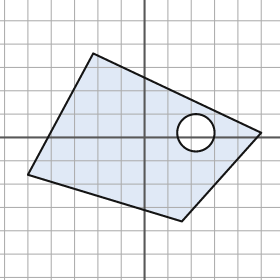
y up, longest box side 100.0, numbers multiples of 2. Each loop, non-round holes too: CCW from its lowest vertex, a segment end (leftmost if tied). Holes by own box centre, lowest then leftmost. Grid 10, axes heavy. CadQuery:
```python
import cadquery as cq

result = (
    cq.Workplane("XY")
    .moveTo(16.0, -36.0)
    .lineTo(50.0, 2.0)
    .lineTo(-22.0, 36.0)
    .lineTo(-50.0, -16.0)
    .close()
    .moveTo(22.0, 2.0)
    .circle(8.0)
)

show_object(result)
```